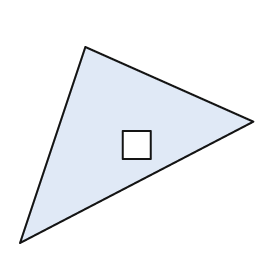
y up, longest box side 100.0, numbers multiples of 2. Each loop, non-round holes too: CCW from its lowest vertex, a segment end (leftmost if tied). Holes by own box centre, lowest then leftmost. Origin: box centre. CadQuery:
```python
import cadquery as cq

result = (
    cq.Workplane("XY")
    .moveTo(-50.0, -42.0)
    .lineTo(50.0, 10.0)
    .lineTo(-22.0, 42.0)
    .close()
    .moveTo(-6.0, -6.0)
    .lineTo(6.0, -6.0)
    .lineTo(6.0, 6.0)
    .lineTo(-6.0, 6.0)
    .close()
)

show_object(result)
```